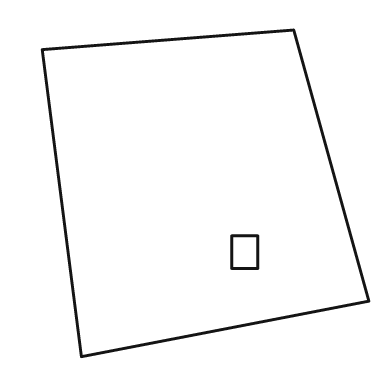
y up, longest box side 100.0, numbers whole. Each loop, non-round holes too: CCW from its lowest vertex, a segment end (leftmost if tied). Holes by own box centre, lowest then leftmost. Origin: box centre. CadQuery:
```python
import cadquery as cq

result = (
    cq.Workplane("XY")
    .moveTo(-38.0, -50.0)
    .lineTo(50.0, -33.0)
    .lineTo(27.0, 50.0)
    .lineTo(-50.0, 44.0)
    .close()
    .moveTo(8.0, -23.0)
    .lineTo(16.0, -23.0)
    .lineTo(16.0, -13.0)
    .lineTo(8.0, -13.0)
    .close()
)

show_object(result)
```